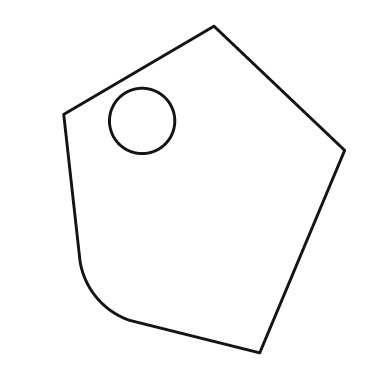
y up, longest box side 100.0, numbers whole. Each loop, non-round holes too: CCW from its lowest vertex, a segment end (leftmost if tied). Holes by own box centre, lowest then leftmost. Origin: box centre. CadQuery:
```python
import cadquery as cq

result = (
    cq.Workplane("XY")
    .moveTo(17.0, -50.0)
    .lineTo(43.0, 12.0)
    .lineTo(3.0, 50.0)
    .lineTo(-43.0, 23.0)
    .lineTo(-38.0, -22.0)
    .threePointArc((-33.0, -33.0), (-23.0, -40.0))
    .close()
    .moveTo(-19.0, 21.0)
    .circle(10.0)
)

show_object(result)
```